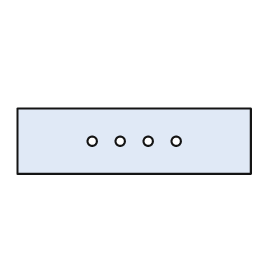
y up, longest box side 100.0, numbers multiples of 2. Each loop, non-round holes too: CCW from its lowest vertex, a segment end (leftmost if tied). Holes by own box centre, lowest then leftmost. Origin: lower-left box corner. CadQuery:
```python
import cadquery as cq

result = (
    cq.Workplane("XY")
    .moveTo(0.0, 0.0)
    .lineTo(100.0, 0.0)
    .lineTo(100.0, 28.0)
    .lineTo(0.0, 28.0)
    .close()
    .moveTo(32.0, 14.0)
    .circle(2.0)
    .moveTo(44.0, 14.0)
    .circle(2.0)
    .moveTo(56.0, 14.0)
    .circle(2.0)
    .moveTo(68.0, 14.0)
    .circle(2.0)
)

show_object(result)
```